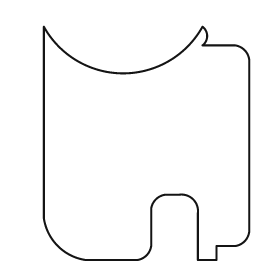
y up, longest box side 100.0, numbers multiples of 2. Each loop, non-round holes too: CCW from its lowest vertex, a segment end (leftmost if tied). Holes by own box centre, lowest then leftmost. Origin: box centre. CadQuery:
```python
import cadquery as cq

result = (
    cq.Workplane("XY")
    .moveTo(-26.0, -50.0)
    .lineTo(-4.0, -50.0)
    .threePointArc((0.0, -48.0), (2.0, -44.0))
    .lineTo(2.0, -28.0)
    .threePointArc((4.0, -24.0), (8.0, -22.0))
    .lineTo(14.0, -22.0)
    .threePointArc((20.0, -24.0), (22.0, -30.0))
    .lineTo(22.0, -50.0)
    .lineTo(30.0, -50.0)
    .lineTo(30.0, -44.0)
    .lineTo(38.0, -44.0)
    .threePointArc((42.0, -42.0), (44.0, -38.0))
    .lineTo(44.0, 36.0)
    .threePointArc((42.0, 40.0), (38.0, 42.0))
    .lineTo(24.0, 42.0)
    .threePointArc((26.0, 46.0), (24.0, 50.0))
    .threePointArc((-10.0, 30.0), (-44.0, 50.0))
    .lineTo(-44.0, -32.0)
    .threePointArc((-38.0, -44.0), (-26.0, -50.0))
    .close()
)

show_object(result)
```